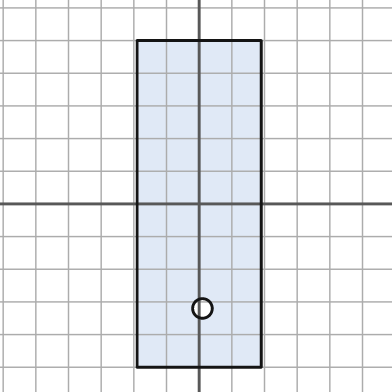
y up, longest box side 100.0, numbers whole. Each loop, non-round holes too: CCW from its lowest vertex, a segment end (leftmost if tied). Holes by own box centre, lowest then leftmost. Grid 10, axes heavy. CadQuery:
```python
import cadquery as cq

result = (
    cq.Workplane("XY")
    .moveTo(-19.0, -50.0)
    .lineTo(19.0, -50.0)
    .lineTo(19.0, 50.0)
    .lineTo(-19.0, 50.0)
    .close()
    .moveTo(1.0, -32.0)
    .circle(3.0)
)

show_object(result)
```